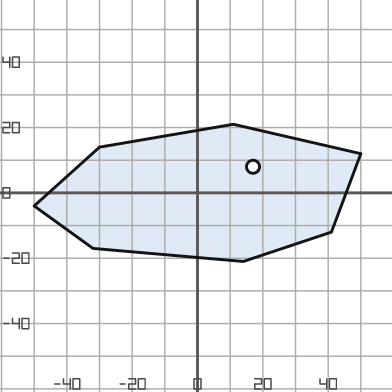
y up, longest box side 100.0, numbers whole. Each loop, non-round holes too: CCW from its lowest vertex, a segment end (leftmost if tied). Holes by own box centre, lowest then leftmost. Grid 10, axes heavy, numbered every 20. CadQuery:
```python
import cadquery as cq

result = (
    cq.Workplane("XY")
    .moveTo(14.0, -21.0)
    .lineTo(41.0, -12.0)
    .lineTo(50.0, 12.0)
    .lineTo(11.0, 21.0)
    .lineTo(-30.0, 14.0)
    .lineTo(-50.0, -4.0)
    .lineTo(-32.0, -17.0)
    .close()
    .moveTo(17.0, 8.0)
    .circle(2.0)
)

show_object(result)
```